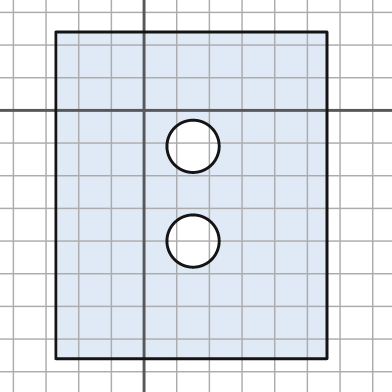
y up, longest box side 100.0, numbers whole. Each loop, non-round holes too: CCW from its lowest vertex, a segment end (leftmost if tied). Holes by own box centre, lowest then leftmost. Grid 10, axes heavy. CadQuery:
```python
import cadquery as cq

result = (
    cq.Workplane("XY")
    .moveTo(-27.0, -76.0)
    .lineTo(56.0, -76.0)
    .lineTo(56.0, 24.0)
    .lineTo(-27.0, 24.0)
    .close()
    .moveTo(15.0, -40.0)
    .circle(8.0)
    .moveTo(15.0, -11.0)
    .circle(8.0)
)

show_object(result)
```